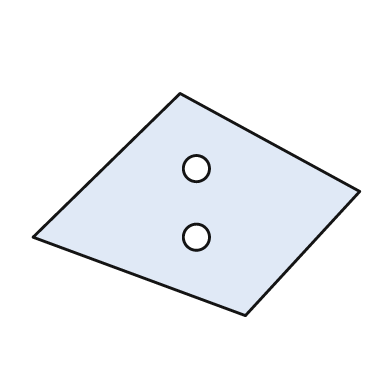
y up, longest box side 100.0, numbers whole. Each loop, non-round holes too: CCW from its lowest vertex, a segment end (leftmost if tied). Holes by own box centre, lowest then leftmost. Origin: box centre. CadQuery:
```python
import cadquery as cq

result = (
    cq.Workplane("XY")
    .moveTo(15.0, -34.0)
    .lineTo(50.0, 4.0)
    .lineTo(-5.0, 34.0)
    .lineTo(-50.0, -10.0)
    .close()
    .moveTo(0.0, -10.0)
    .circle(4.0)
    .moveTo(0.0, 11.0)
    .circle(4.0)
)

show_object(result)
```